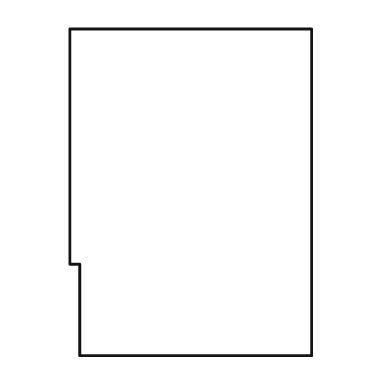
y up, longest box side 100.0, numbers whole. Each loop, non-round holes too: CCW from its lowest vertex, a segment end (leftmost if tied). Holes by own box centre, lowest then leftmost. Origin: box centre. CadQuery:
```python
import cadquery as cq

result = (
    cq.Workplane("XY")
    .moveTo(-34.0, -50.0)
    .lineTo(37.0, -50.0)
    .lineTo(37.0, 50.0)
    .lineTo(-37.0, 50.0)
    .lineTo(-37.0, -22.0)
    .lineTo(-34.0, -22.0)
    .close()
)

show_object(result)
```